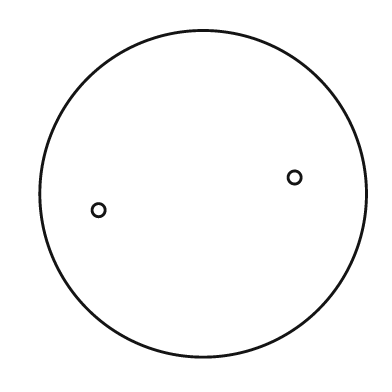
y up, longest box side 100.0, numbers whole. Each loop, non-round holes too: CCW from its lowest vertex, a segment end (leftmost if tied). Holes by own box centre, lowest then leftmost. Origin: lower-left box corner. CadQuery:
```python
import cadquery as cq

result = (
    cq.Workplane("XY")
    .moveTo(50.0, 50.0)
    .circle(50.0)
    .moveTo(18.0, 45.0)
    .circle(2.0)
    .moveTo(78.0, 55.0)
    .circle(2.0)
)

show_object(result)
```